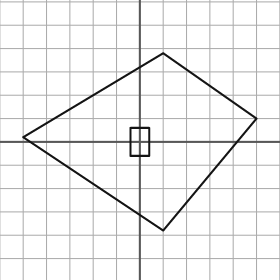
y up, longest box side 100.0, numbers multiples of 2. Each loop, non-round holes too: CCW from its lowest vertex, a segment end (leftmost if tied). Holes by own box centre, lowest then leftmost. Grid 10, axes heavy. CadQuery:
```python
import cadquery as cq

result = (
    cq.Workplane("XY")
    .moveTo(10.0, -38.0)
    .lineTo(50.0, 10.0)
    .lineTo(10.0, 38.0)
    .lineTo(-50.0, 2.0)
    .close()
    .moveTo(-4.0, -6.0)
    .lineTo(4.0, -6.0)
    .lineTo(4.0, 6.0)
    .lineTo(-4.0, 6.0)
    .close()
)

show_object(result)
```